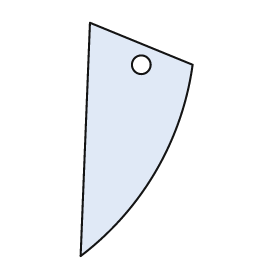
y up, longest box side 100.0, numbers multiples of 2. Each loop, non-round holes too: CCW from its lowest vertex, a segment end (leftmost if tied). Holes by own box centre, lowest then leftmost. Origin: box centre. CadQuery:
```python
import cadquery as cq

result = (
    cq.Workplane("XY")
    .moveTo(-24.0, -50.0)
    .threePointArc((8.0, -14.0), (24.0, 32.0))
    .lineTo(-20.0, 50.0)
    .close()
    .moveTo(2.0, 32.0)
    .circle(4.0)
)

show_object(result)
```